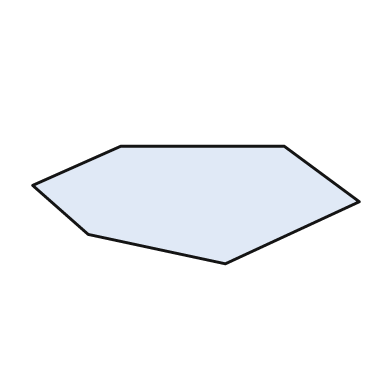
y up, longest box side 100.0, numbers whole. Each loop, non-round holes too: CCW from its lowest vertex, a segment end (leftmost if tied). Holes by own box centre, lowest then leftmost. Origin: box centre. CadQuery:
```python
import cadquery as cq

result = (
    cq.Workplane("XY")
    .moveTo(9.0, -18.0)
    .lineTo(50.0, 1.0)
    .lineTo(27.0, 18.0)
    .lineTo(-23.0, 18.0)
    .lineTo(-50.0, 6.0)
    .lineTo(-33.0, -9.0)
    .close()
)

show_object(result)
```